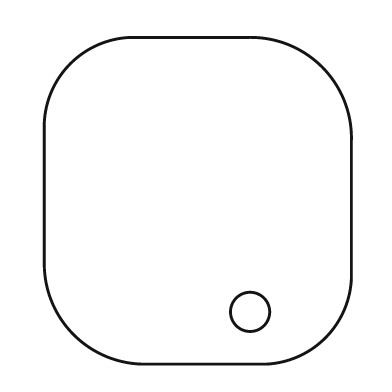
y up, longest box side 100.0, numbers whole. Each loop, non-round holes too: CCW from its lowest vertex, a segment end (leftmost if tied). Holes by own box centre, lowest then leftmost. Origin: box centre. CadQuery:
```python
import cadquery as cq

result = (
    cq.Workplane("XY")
    .moveTo(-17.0, -50.0)
    .lineTo(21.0, -50.0)
    .threePointArc((39.0, -42.0), (47.0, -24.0))
    .lineTo(47.0, 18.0)
    .threePointArc((38.0, 41.0), (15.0, 50.0))
    .lineTo(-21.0, 50.0)
    .threePointArc((-39.0, 42.0), (-47.0, 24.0))
    .lineTo(-47.0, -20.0)
    .threePointArc((-38.0, -41.0), (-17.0, -50.0))
    .close()
    .moveTo(16.0, -34.0)
    .circle(6.0)
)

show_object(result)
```